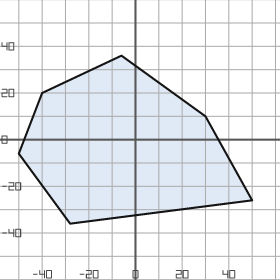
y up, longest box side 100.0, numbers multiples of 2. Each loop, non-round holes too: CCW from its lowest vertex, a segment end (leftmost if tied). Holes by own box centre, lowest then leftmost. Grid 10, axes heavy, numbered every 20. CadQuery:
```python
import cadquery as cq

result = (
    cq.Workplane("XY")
    .moveTo(-28.0, -36.0)
    .lineTo(50.0, -26.0)
    .lineTo(30.0, 10.0)
    .lineTo(-6.0, 36.0)
    .lineTo(-40.0, 20.0)
    .lineTo(-50.0, -6.0)
    .close()
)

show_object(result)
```